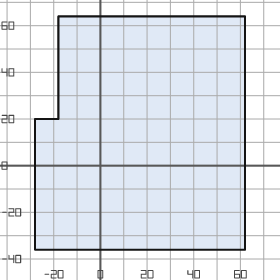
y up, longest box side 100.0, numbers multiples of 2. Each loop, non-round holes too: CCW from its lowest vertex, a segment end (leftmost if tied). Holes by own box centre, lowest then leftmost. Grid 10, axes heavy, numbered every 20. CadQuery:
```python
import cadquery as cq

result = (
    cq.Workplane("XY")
    .moveTo(-28.0, -36.0)
    .lineTo(62.0, -36.0)
    .lineTo(62.0, 64.0)
    .lineTo(-18.0, 64.0)
    .lineTo(-18.0, 20.0)
    .lineTo(-28.0, 20.0)
    .close()
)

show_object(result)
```